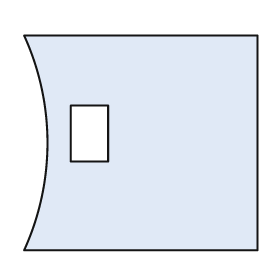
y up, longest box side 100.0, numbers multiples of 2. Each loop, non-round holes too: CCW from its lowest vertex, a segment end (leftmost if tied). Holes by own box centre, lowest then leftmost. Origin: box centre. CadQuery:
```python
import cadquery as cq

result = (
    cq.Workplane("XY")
    .moveTo(-50.0, -46.0)
    .lineTo(50.0, -46.0)
    .lineTo(50.0, 46.0)
    .lineTo(-50.0, 46.0)
    .threePointArc((-40.0, 0.0), (-50.0, -46.0))
    .close()
    .moveTo(-30.0, -8.0)
    .lineTo(-14.0, -8.0)
    .lineTo(-14.0, 16.0)
    .lineTo(-30.0, 16.0)
    .close()
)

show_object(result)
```